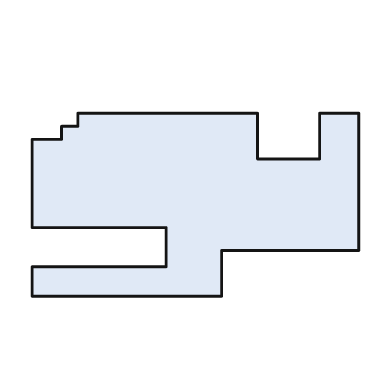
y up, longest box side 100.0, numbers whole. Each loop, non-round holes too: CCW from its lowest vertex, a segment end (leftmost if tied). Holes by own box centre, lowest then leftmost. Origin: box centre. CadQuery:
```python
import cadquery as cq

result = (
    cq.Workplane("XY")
    .moveTo(-50.0, -28.0)
    .lineTo(8.0, -28.0)
    .lineTo(8.0, -14.0)
    .lineTo(50.0, -14.0)
    .lineTo(50.0, 28.0)
    .lineTo(38.0, 28.0)
    .lineTo(38.0, 14.0)
    .lineTo(19.0, 14.0)
    .lineTo(19.0, 28.0)
    .lineTo(-36.0, 28.0)
    .lineTo(-36.0, 24.0)
    .lineTo(-41.0, 24.0)
    .lineTo(-41.0, 20.0)
    .lineTo(-50.0, 20.0)
    .lineTo(-50.0, -7.0)
    .lineTo(-9.0, -7.0)
    .lineTo(-9.0, -19.0)
    .lineTo(-50.0, -19.0)
    .close()
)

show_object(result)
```